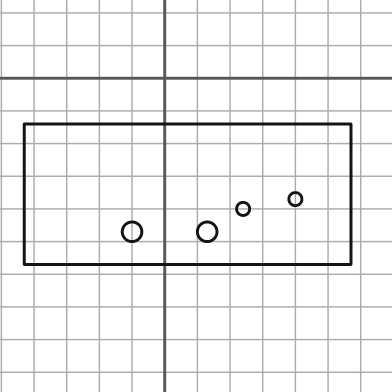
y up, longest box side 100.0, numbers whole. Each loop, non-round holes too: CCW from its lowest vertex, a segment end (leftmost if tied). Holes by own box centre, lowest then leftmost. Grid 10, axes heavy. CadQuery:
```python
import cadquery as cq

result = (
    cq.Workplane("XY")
    .moveTo(-43.0, -57.0)
    .lineTo(57.0, -57.0)
    .lineTo(57.0, -14.0)
    .lineTo(-43.0, -14.0)
    .close()
    .moveTo(-10.0, -47.0)
    .circle(3.0)
    .moveTo(13.0, -47.0)
    .circle(3.0)
    .moveTo(24.0, -40.0)
    .circle(2.0)
    .moveTo(40.0, -37.0)
    .circle(2.0)
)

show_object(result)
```